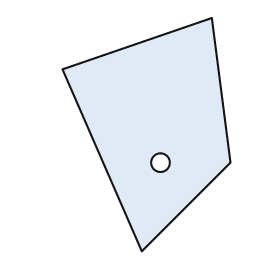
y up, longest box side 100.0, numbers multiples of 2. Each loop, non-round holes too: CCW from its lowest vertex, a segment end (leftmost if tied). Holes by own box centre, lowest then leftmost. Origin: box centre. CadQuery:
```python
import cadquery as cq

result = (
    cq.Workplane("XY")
    .moveTo(-2.0, -50.0)
    .lineTo(36.0, -12.0)
    .lineTo(28.0, 50.0)
    .lineTo(-36.0, 28.0)
    .close()
    .moveTo(6.0, -12.0)
    .circle(4.0)
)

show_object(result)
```